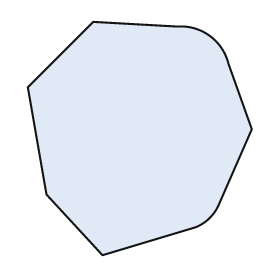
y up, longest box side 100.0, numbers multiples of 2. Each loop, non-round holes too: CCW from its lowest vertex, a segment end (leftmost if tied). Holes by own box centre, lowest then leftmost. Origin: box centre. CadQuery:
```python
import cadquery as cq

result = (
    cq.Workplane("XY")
    .moveTo(-16.0, -50.0)
    .lineTo(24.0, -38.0)
    .threePointArc((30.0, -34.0), (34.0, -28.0))
    .lineTo(48.0, 4.0)
    .lineTo(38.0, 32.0)
    .threePointArc((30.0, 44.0), (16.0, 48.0))
    .lineTo(-20.0, 50.0)
    .lineTo(-48.0, 22.0)
    .lineTo(-40.0, -24.0)
    .close()
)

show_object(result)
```